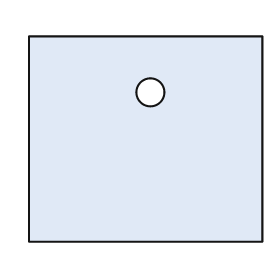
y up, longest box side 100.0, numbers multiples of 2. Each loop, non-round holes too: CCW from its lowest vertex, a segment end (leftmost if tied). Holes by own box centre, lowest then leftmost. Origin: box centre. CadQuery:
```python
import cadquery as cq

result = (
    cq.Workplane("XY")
    .moveTo(-50.0, -44.0)
    .lineTo(50.0, -44.0)
    .lineTo(50.0, 44.0)
    .lineTo(-50.0, 44.0)
    .close()
    .moveTo(2.0, 20.0)
    .circle(6.0)
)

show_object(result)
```